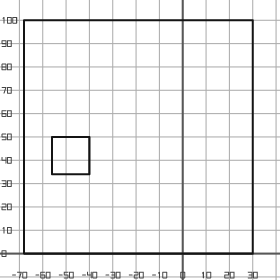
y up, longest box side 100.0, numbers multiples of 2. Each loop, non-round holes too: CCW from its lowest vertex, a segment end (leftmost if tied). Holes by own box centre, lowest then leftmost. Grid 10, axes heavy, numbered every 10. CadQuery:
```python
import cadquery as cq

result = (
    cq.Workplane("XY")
    .moveTo(-68.0, 0.0)
    .lineTo(30.0, 0.0)
    .lineTo(30.0, 100.0)
    .lineTo(-68.0, 100.0)
    .close()
    .moveTo(-56.0, 34.0)
    .lineTo(-40.0, 34.0)
    .lineTo(-40.0, 50.0)
    .lineTo(-56.0, 50.0)
    .close()
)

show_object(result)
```